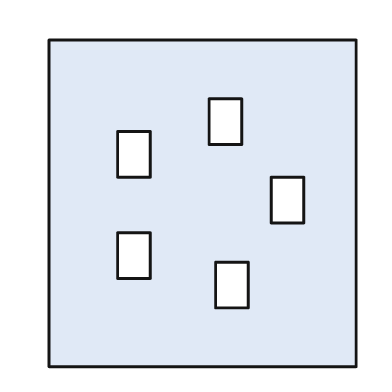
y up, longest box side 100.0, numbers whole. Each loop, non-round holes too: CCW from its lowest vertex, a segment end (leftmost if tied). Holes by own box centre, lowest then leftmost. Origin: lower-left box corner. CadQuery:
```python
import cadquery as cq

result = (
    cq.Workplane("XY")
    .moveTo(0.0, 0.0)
    .lineTo(94.0, 0.0)
    .lineTo(94.0, 100.0)
    .lineTo(0.0, 100.0)
    .close()
    .moveTo(51.0, 18.0)
    .lineTo(61.0, 18.0)
    .lineTo(61.0, 32.0)
    .lineTo(51.0, 32.0)
    .close()
    .moveTo(21.0, 27.0)
    .lineTo(31.0, 27.0)
    .lineTo(31.0, 41.0)
    .lineTo(21.0, 41.0)
    .close()
    .moveTo(68.0, 44.0)
    .lineTo(78.0, 44.0)
    .lineTo(78.0, 58.0)
    .lineTo(68.0, 58.0)
    .close()
    .moveTo(21.0, 58.0)
    .lineTo(31.0, 58.0)
    .lineTo(31.0, 72.0)
    .lineTo(21.0, 72.0)
    .close()
    .moveTo(49.0, 68.0)
    .lineTo(59.0, 68.0)
    .lineTo(59.0, 82.0)
    .lineTo(49.0, 82.0)
    .close()
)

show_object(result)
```